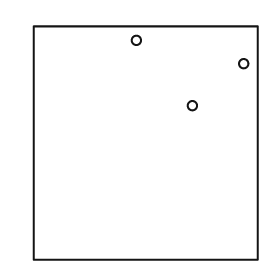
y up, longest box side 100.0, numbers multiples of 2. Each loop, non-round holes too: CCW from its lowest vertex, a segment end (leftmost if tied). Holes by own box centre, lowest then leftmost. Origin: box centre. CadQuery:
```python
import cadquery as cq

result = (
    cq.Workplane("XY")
    .moveTo(-48.0, -50.0)
    .lineTo(48.0, -50.0)
    .lineTo(48.0, 50.0)
    .lineTo(-48.0, 50.0)
    .close()
    .moveTo(20.0, 16.0)
    .circle(2.0)
    .moveTo(42.0, 34.0)
    .circle(2.0)
    .moveTo(-4.0, 44.0)
    .circle(2.0)
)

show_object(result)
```